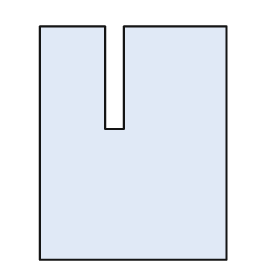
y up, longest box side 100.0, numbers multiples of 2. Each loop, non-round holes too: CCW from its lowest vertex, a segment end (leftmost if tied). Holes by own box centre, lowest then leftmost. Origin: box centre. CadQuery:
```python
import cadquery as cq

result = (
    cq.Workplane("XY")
    .moveTo(-40.0, -50.0)
    .lineTo(40.0, -50.0)
    .lineTo(40.0, 50.0)
    .lineTo(-4.0, 50.0)
    .lineTo(-4.0, 6.0)
    .lineTo(-12.0, 6.0)
    .lineTo(-12.0, 50.0)
    .lineTo(-40.0, 50.0)
    .close()
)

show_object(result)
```